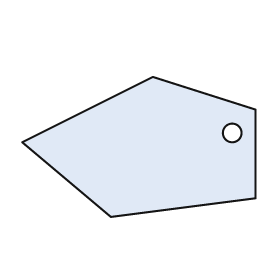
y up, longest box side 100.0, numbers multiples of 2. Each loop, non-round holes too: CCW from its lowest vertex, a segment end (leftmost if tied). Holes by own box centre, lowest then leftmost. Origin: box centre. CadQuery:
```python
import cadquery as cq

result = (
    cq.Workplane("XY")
    .moveTo(-12.0, -30.0)
    .lineTo(50.0, -22.0)
    .lineTo(50.0, 16.0)
    .lineTo(6.0, 30.0)
    .lineTo(-50.0, 2.0)
    .close()
    .moveTo(40.0, 6.0)
    .circle(4.0)
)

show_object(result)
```